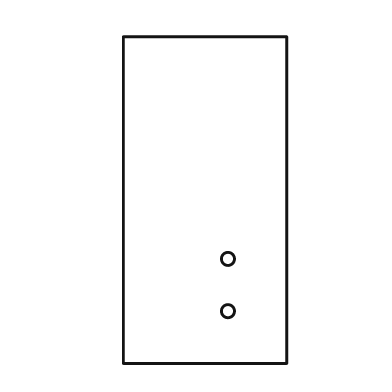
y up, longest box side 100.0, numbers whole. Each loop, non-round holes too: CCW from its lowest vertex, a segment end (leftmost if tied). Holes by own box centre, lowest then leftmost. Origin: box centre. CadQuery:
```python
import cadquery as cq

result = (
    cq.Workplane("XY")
    .moveTo(-25.0, -50.0)
    .lineTo(25.0, -50.0)
    .lineTo(25.0, 50.0)
    .lineTo(-25.0, 50.0)
    .close()
    .moveTo(7.0, -34.0)
    .circle(2.0)
    .moveTo(7.0, -18.0)
    .circle(2.0)
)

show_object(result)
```